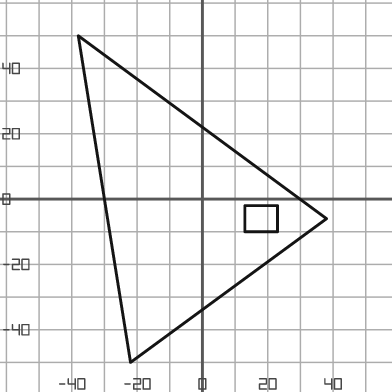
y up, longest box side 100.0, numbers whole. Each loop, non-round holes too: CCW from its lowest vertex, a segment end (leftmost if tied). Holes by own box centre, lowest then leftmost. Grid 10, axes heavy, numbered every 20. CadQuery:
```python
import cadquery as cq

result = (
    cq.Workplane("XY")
    .moveTo(-22.0, -50.0)
    .lineTo(38.0, -6.0)
    .lineTo(-38.0, 50.0)
    .close()
    .moveTo(13.0, -10.0)
    .lineTo(23.0, -10.0)
    .lineTo(23.0, -2.0)
    .lineTo(13.0, -2.0)
    .close()
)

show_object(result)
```